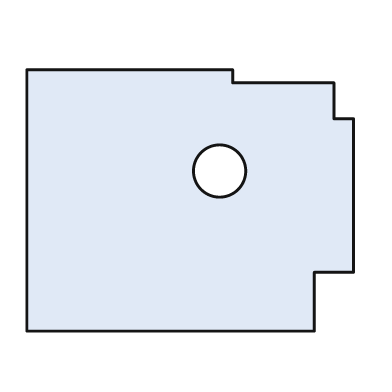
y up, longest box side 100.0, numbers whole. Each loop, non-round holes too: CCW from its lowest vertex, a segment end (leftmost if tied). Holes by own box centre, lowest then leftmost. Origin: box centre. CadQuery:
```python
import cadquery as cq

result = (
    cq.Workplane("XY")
    .moveTo(-50.0, -40.0)
    .lineTo(38.0, -40.0)
    .lineTo(38.0, -22.0)
    .lineTo(50.0, -22.0)
    .lineTo(50.0, 25.0)
    .lineTo(44.0, 25.0)
    .lineTo(44.0, 36.0)
    .lineTo(13.0, 36.0)
    .lineTo(13.0, 40.0)
    .lineTo(-50.0, 40.0)
    .close()
    .moveTo(9.0, 9.0)
    .circle(8.0)
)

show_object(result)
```